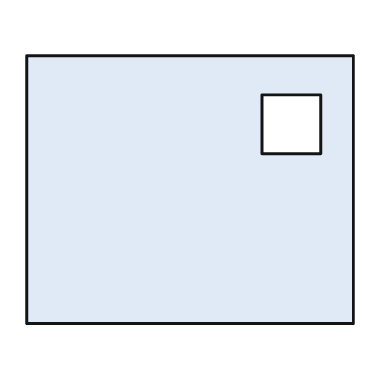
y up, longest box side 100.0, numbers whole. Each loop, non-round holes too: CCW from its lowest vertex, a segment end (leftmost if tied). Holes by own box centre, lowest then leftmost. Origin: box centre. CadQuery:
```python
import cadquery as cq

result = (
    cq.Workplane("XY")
    .moveTo(-50.0, -41.0)
    .lineTo(50.0, -41.0)
    .lineTo(50.0, 41.0)
    .lineTo(-50.0, 41.0)
    .close()
    .moveTo(22.0, 11.0)
    .lineTo(40.0, 11.0)
    .lineTo(40.0, 29.0)
    .lineTo(22.0, 29.0)
    .close()
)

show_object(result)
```